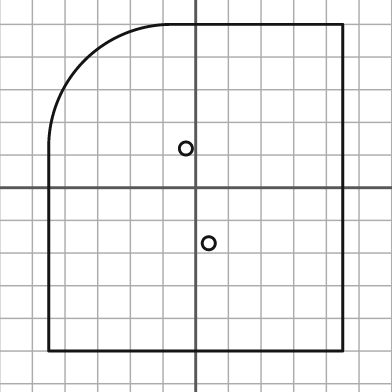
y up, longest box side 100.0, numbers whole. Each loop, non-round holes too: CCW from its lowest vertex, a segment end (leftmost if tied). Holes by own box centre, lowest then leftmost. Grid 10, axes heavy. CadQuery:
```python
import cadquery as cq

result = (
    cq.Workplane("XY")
    .moveTo(-45.0, -50.0)
    .lineTo(45.0, -50.0)
    .lineTo(45.0, 50.0)
    .lineTo(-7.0, 50.0)
    .threePointArc((-34.0, 39.0), (-45.0, 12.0))
    .close()
    .moveTo(4.0, -17.0)
    .circle(2.0)
    .moveTo(-3.0, 12.0)
    .circle(2.0)
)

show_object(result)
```